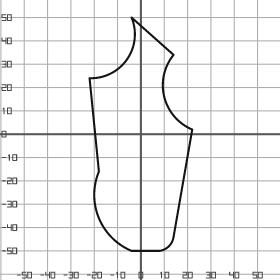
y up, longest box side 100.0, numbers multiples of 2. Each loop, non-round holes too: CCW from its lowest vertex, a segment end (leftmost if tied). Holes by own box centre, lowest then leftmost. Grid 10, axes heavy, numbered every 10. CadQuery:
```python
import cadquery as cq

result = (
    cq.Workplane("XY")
    .moveTo(-4.0, -50.0)
    .lineTo(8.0, -50.0)
    .threePointArc((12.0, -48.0), (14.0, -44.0))
    .lineTo(22.0, 2.0)
    .threePointArc((10.0, 16.0), (14.0, 34.0))
    .lineTo(-4.0, 50.0)
    .threePointArc((-6.0, 32.0), (-22.0, 24.0))
    .lineTo(-18.0, -16.0)
    .threePointArc((-18.0, -36.0), (-4.0, -50.0))
    .close()
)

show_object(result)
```